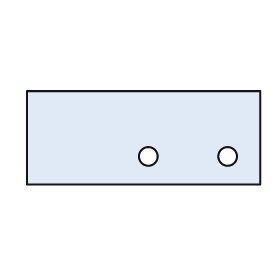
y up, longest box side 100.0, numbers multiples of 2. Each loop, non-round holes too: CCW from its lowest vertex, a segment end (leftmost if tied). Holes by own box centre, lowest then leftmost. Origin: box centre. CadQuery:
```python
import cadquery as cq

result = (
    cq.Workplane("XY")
    .moveTo(-50.0, -20.0)
    .lineTo(50.0, -20.0)
    .lineTo(50.0, 20.0)
    .lineTo(-50.0, 20.0)
    .close()
    .moveTo(2.0, -8.0)
    .circle(4.0)
    .moveTo(36.0, -8.0)
    .circle(4.0)
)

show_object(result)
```